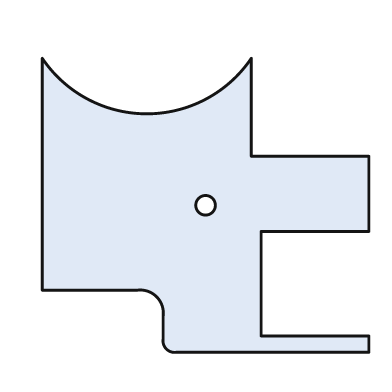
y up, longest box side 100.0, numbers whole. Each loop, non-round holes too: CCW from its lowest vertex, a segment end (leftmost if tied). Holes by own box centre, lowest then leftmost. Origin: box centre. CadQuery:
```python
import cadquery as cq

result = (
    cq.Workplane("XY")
    .moveTo(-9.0, -45.0)
    .lineTo(50.0, -45.0)
    .lineTo(50.0, -40.0)
    .lineTo(17.0, -40.0)
    .lineTo(17.0, -8.0)
    .lineTo(50.0, -8.0)
    .lineTo(50.0, 15.0)
    .lineTo(14.0, 15.0)
    .lineTo(14.0, 45.0)
    .threePointArc((-18.0, 28.0), (-50.0, 45.0))
    .lineTo(-50.0, -26.0)
    .lineTo(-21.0, -26.0)
    .threePointArc((-15.0, -28.0), (-13.0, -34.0))
    .lineTo(-13.0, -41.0)
    .threePointArc((-12.0, -44.0), (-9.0, -45.0))
    .close()
    .moveTo(0.0, 0.0)
    .circle(3.0)
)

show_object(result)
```